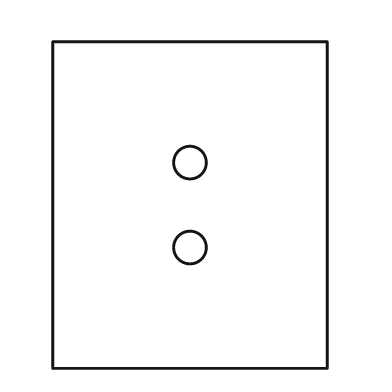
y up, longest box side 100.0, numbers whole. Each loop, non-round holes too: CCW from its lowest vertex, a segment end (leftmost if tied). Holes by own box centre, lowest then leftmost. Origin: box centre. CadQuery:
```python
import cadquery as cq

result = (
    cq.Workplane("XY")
    .moveTo(-42.0, -50.0)
    .lineTo(42.0, -50.0)
    .lineTo(42.0, 50.0)
    .lineTo(-42.0, 50.0)
    .close()
    .moveTo(0.0, -13.0)
    .circle(5.0)
    .moveTo(0.0, 13.0)
    .circle(5.0)
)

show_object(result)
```